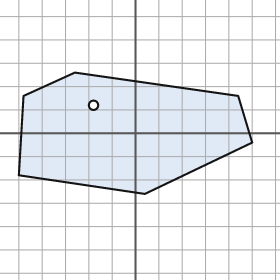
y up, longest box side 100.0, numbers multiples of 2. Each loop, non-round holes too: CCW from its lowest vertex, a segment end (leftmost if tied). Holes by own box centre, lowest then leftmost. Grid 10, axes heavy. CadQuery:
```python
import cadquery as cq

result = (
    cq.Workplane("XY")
    .moveTo(4.0, -26.0)
    .lineTo(50.0, -4.0)
    .lineTo(44.0, 16.0)
    .lineTo(-26.0, 26.0)
    .lineTo(-48.0, 16.0)
    .lineTo(-50.0, -18.0)
    .close()
    .moveTo(-18.0, 12.0)
    .circle(2.0)
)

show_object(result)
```